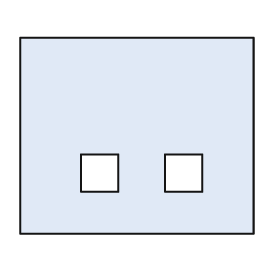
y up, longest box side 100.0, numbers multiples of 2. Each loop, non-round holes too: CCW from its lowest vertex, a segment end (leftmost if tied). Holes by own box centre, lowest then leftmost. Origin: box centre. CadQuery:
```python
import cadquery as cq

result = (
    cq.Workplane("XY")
    .moveTo(-50.0, -42.0)
    .lineTo(50.0, -42.0)
    .lineTo(50.0, 42.0)
    .lineTo(-50.0, 42.0)
    .close()
    .moveTo(-24.0, -24.0)
    .lineTo(-8.0, -24.0)
    .lineTo(-8.0, -8.0)
    .lineTo(-24.0, -8.0)
    .close()
    .moveTo(12.0, -24.0)
    .lineTo(28.0, -24.0)
    .lineTo(28.0, -8.0)
    .lineTo(12.0, -8.0)
    .close()
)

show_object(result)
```